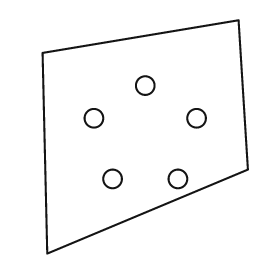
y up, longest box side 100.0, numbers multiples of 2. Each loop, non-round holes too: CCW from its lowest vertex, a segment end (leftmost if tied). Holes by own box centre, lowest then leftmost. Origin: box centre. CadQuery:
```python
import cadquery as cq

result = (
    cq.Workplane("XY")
    .moveTo(-42.0, -50.0)
    .lineTo(44.0, -14.0)
    .lineTo(40.0, 50.0)
    .lineTo(-44.0, 36.0)
    .close()
    .moveTo(-14.0, -18.0)
    .circle(4.0)
    .moveTo(14.0, -18.0)
    .circle(4.0)
    .moveTo(-22.0, 8.0)
    .circle(4.0)
    .moveTo(22.0, 8.0)
    .circle(4.0)
    .moveTo(0.0, 22.0)
    .circle(4.0)
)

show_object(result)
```